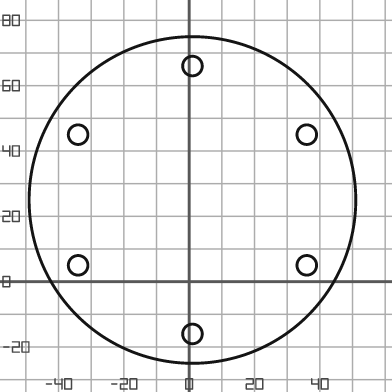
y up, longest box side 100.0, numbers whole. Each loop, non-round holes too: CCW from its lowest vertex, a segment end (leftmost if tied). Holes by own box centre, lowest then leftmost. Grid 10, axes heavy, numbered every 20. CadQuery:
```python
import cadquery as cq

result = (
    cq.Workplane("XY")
    .moveTo(1.0, 25.0)
    .circle(50.0)
    .moveTo(1.0, -16.0)
    .circle(3.0)
    .moveTo(-34.0, 5.0)
    .circle(3.0)
    .moveTo(36.0, 5.0)
    .circle(3.0)
    .moveTo(-34.0, 45.0)
    .circle(3.0)
    .moveTo(36.0, 45.0)
    .circle(3.0)
    .moveTo(1.0, 66.0)
    .circle(3.0)
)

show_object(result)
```